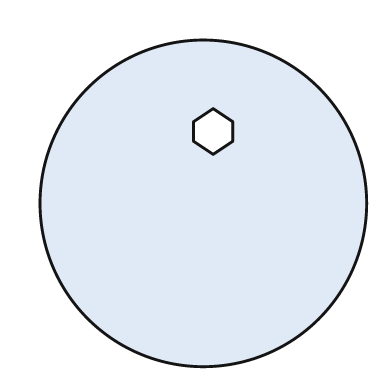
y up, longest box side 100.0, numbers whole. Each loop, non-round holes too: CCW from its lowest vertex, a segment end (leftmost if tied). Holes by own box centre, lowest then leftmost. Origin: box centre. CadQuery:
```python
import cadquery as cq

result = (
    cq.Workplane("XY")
    .moveTo(0.0, 0.0)
    .circle(50.0)
    .moveTo(3.0, 15.0)
    .lineTo(9.0, 19.0)
    .lineTo(9.0, 25.0)
    .lineTo(3.0, 29.0)
    .lineTo(-3.0, 25.0)
    .lineTo(-3.0, 19.0)
    .close()
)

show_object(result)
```